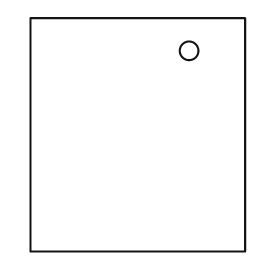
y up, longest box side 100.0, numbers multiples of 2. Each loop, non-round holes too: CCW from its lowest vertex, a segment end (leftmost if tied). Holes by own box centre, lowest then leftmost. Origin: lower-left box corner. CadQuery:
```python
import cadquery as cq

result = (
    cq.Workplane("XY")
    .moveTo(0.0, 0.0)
    .lineTo(92.0, 0.0)
    .lineTo(92.0, 100.0)
    .lineTo(0.0, 100.0)
    .close()
    .moveTo(68.0, 86.0)
    .circle(4.0)
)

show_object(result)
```